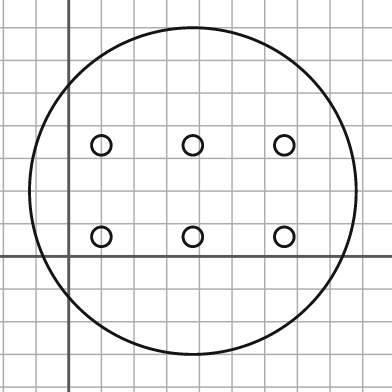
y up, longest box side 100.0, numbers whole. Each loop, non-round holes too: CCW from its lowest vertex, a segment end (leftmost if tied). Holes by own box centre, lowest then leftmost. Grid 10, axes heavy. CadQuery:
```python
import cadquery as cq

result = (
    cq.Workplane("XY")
    .moveTo(38.0, 20.0)
    .circle(50.0)
    .moveTo(10.0, 6.0)
    .circle(3.0)
    .moveTo(38.0, 6.0)
    .circle(3.0)
    .moveTo(66.0, 6.0)
    .circle(3.0)
    .moveTo(10.0, 34.0)
    .circle(3.0)
    .moveTo(38.0, 34.0)
    .circle(3.0)
    .moveTo(66.0, 34.0)
    .circle(3.0)
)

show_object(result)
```